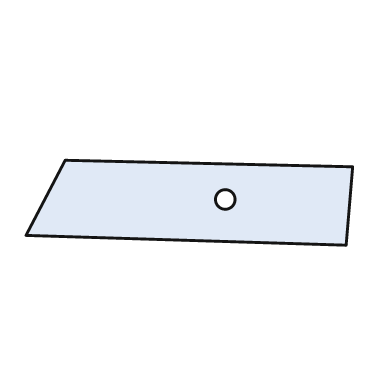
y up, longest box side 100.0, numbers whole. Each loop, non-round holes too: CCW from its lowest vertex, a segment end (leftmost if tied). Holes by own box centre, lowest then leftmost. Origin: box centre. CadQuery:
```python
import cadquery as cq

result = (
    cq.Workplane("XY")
    .moveTo(48.0, -13.0)
    .lineTo(50.0, 11.0)
    .lineTo(-38.0, 13.0)
    .lineTo(-50.0, -10.0)
    .close()
    .moveTo(11.0, 1.0)
    .circle(3.0)
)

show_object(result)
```